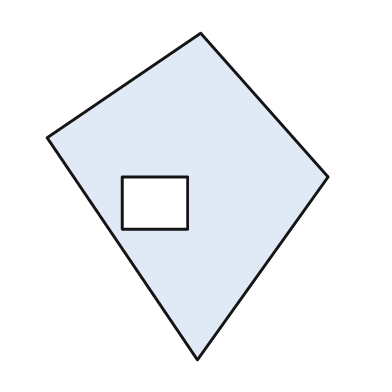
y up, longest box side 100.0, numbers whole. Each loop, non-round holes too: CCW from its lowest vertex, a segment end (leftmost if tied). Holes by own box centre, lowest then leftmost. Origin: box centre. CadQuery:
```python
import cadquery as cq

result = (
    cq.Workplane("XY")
    .moveTo(3.0, -50.0)
    .lineTo(43.0, 6.0)
    .lineTo(4.0, 50.0)
    .lineTo(-43.0, 18.0)
    .close()
    .moveTo(-20.0, -10.0)
    .lineTo(0.0, -10.0)
    .lineTo(0.0, 6.0)
    .lineTo(-20.0, 6.0)
    .close()
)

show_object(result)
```